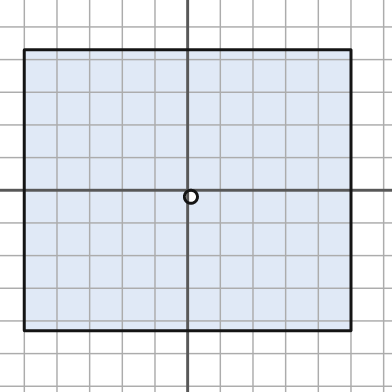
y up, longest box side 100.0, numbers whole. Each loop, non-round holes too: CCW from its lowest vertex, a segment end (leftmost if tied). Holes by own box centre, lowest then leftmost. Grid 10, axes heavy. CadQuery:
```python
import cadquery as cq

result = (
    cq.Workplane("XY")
    .moveTo(-50.0, -43.0)
    .lineTo(50.0, -43.0)
    .lineTo(50.0, 43.0)
    .lineTo(-50.0, 43.0)
    .close()
    .moveTo(1.0, -2.0)
    .circle(2.0)
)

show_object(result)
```